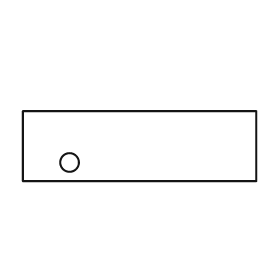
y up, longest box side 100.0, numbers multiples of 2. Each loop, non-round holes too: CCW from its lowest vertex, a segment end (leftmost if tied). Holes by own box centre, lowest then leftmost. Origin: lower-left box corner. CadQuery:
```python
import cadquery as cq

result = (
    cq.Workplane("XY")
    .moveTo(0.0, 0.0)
    .lineTo(100.0, 0.0)
    .lineTo(100.0, 30.0)
    .lineTo(0.0, 30.0)
    .close()
    .moveTo(20.0, 8.0)
    .circle(4.0)
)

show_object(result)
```